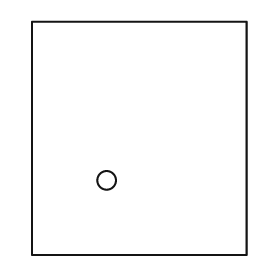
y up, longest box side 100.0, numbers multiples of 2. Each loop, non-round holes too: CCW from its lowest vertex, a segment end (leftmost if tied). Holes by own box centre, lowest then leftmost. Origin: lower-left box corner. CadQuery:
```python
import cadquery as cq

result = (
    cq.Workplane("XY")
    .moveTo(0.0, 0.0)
    .lineTo(92.0, 0.0)
    .lineTo(92.0, 100.0)
    .lineTo(0.0, 100.0)
    .close()
    .moveTo(32.0, 32.0)
    .circle(4.0)
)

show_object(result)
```